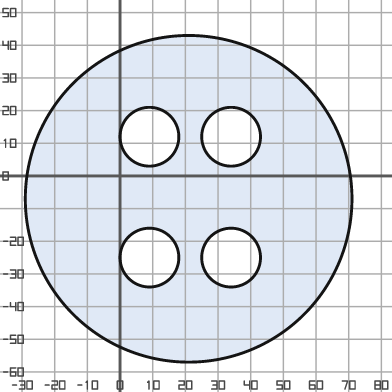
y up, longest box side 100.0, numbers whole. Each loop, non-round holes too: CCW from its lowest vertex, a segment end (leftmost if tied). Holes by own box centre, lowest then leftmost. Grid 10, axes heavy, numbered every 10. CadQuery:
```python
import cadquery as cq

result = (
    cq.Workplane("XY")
    .moveTo(21.0, -7.0)
    .circle(50.0)
    .moveTo(9.0, -25.0)
    .circle(9.0)
    .moveTo(34.0, -25.0)
    .circle(9.0)
    .moveTo(9.0, 12.0)
    .circle(9.0)
    .moveTo(34.0, 12.0)
    .circle(9.0)
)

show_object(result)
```